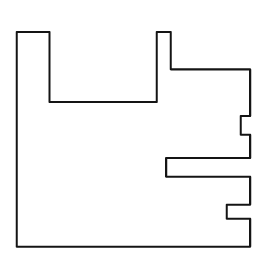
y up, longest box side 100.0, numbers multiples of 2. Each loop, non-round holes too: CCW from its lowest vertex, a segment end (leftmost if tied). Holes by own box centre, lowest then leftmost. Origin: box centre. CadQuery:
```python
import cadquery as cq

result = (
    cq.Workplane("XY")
    .moveTo(-50.0, -46.0)
    .lineTo(50.0, -46.0)
    .lineTo(50.0, -34.0)
    .lineTo(40.0, -34.0)
    .lineTo(40.0, -28.0)
    .lineTo(50.0, -28.0)
    .lineTo(50.0, -16.0)
    .lineTo(14.0, -16.0)
    .lineTo(14.0, -8.0)
    .lineTo(50.0, -8.0)
    .lineTo(50.0, 2.0)
    .lineTo(46.0, 2.0)
    .lineTo(46.0, 10.0)
    .lineTo(50.0, 10.0)
    .lineTo(50.0, 30.0)
    .lineTo(16.0, 30.0)
    .lineTo(16.0, 46.0)
    .lineTo(10.0, 46.0)
    .lineTo(10.0, 16.0)
    .lineTo(-36.0, 16.0)
    .lineTo(-36.0, 46.0)
    .lineTo(-50.0, 46.0)
    .close()
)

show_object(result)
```